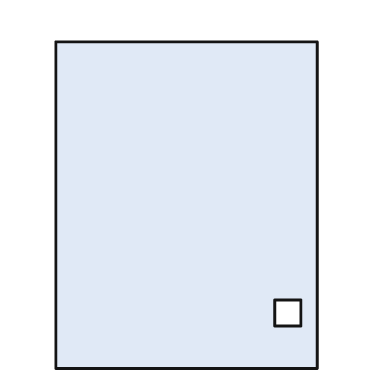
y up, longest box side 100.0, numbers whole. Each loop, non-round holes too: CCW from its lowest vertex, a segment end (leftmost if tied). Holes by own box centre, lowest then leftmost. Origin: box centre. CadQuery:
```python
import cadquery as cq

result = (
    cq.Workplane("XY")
    .moveTo(-40.0, -50.0)
    .lineTo(40.0, -50.0)
    .lineTo(40.0, 50.0)
    .lineTo(-40.0, 50.0)
    .close()
    .moveTo(27.0, -37.0)
    .lineTo(35.0, -37.0)
    .lineTo(35.0, -29.0)
    .lineTo(27.0, -29.0)
    .close()
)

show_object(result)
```